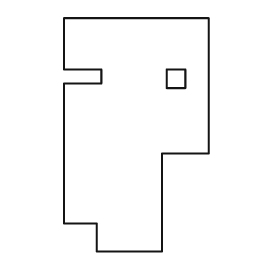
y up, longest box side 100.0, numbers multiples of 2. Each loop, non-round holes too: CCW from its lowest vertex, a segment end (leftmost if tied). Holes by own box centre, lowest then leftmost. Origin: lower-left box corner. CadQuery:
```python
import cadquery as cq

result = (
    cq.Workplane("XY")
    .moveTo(14.0, 0.0)
    .lineTo(42.0, 0.0)
    .lineTo(42.0, 42.0)
    .lineTo(62.0, 42.0)
    .lineTo(62.0, 100.0)
    .lineTo(0.0, 100.0)
    .lineTo(0.0, 78.0)
    .lineTo(16.0, 78.0)
    .lineTo(16.0, 72.0)
    .lineTo(0.0, 72.0)
    .lineTo(0.0, 12.0)
    .lineTo(14.0, 12.0)
    .close()
    .moveTo(44.0, 70.0)
    .lineTo(52.0, 70.0)
    .lineTo(52.0, 78.0)
    .lineTo(44.0, 78.0)
    .close()
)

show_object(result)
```